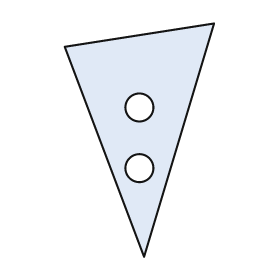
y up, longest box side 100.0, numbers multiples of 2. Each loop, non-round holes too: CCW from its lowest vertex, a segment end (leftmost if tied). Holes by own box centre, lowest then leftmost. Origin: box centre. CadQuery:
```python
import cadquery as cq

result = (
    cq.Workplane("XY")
    .moveTo(2.0, -50.0)
    .lineTo(32.0, 50.0)
    .lineTo(-32.0, 40.0)
    .close()
    .moveTo(0.0, -12.0)
    .circle(6.0)
    .moveTo(0.0, 14.0)
    .circle(6.0)
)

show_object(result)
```